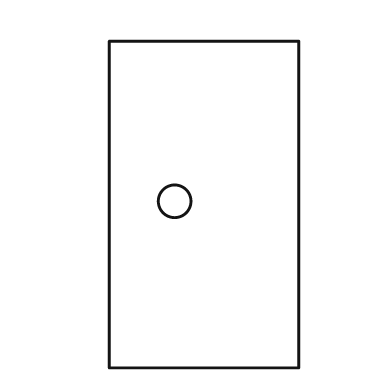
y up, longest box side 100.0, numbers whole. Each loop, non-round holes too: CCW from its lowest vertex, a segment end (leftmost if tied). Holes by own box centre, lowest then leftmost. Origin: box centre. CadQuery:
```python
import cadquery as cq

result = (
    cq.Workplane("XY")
    .moveTo(-29.0, -50.0)
    .lineTo(29.0, -50.0)
    .lineTo(29.0, 50.0)
    .lineTo(-29.0, 50.0)
    .close()
    .moveTo(-9.0, 1.0)
    .circle(5.0)
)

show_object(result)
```